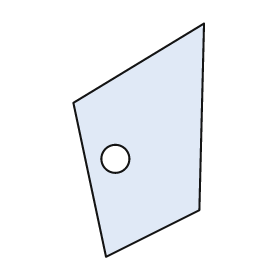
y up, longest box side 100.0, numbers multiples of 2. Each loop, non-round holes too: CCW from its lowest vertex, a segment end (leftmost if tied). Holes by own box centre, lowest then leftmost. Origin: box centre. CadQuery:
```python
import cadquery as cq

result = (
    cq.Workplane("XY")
    .moveTo(-14.0, -50.0)
    .lineTo(26.0, -30.0)
    .lineTo(28.0, 50.0)
    .lineTo(-28.0, 16.0)
    .close()
    .moveTo(-10.0, -8.0)
    .circle(6.0)
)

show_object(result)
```